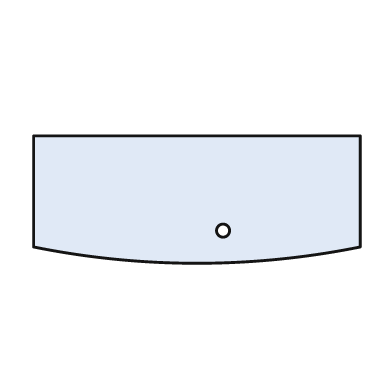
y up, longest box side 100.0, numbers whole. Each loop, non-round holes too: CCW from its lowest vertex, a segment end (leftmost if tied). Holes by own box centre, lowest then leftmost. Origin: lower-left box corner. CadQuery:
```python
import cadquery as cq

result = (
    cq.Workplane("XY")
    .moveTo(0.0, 5.0)
    .threePointArc((50.0, 0.0), (100.0, 5.0))
    .lineTo(100.0, 39.0)
    .lineTo(0.0, 39.0)
    .close()
    .moveTo(58.0, 10.0)
    .circle(2.0)
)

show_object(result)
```